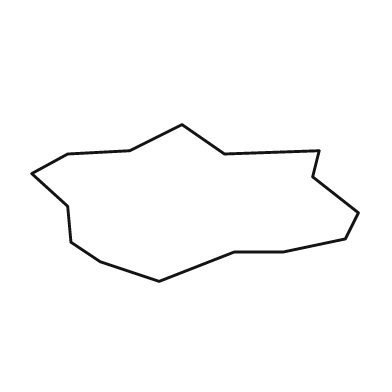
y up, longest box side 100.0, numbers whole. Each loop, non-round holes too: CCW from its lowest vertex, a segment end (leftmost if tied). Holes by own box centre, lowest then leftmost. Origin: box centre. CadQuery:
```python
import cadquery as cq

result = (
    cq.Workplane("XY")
    .moveTo(-11.0, -24.0)
    .lineTo(12.0, -15.0)
    .lineTo(27.0, -15.0)
    .lineTo(46.0, -11.0)
    .lineTo(50.0, -3.0)
    .lineTo(36.0, 8.0)
    .lineTo(38.0, 16.0)
    .lineTo(9.0, 15.0)
    .lineTo(-4.0, 24.0)
    .lineTo(-20.0, 16.0)
    .lineTo(-39.0, 15.0)
    .lineTo(-50.0, 9.0)
    .lineTo(-39.0, -1.0)
    .lineTo(-38.0, -12.0)
    .lineTo(-29.0, -18.0)
    .close()
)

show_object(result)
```